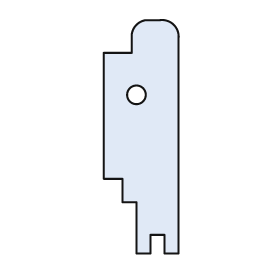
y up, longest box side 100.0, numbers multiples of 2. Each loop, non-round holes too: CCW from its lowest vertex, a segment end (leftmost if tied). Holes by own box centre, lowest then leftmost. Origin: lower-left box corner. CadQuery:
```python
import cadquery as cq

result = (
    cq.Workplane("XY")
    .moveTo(14.0, 0.0)
    .lineTo(20.0, 0.0)
    .lineTo(20.0, 8.0)
    .lineTo(26.0, 8.0)
    .lineTo(26.0, 0.0)
    .lineTo(32.0, 0.0)
    .lineTo(32.0, 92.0)
    .threePointArc((30.0, 98.0), (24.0, 100.0))
    .lineTo(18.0, 100.0)
    .threePointArc((14.0, 98.0), (12.0, 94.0))
    .lineTo(12.0, 86.0)
    .lineTo(0.0, 86.0)
    .lineTo(0.0, 32.0)
    .lineTo(8.0, 32.0)
    .lineTo(8.0, 22.0)
    .lineTo(14.0, 22.0)
    .close()
    .moveTo(14.0, 68.0)
    .circle(4.0)
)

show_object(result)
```